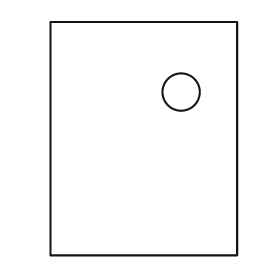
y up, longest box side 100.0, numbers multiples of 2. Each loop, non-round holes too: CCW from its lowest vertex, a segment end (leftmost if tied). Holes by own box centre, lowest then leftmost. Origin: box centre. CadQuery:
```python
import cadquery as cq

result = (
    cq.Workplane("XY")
    .moveTo(-40.0, -50.0)
    .lineTo(40.0, -50.0)
    .lineTo(40.0, 50.0)
    .lineTo(-40.0, 50.0)
    .close()
    .moveTo(16.0, 20.0)
    .circle(8.0)
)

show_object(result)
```